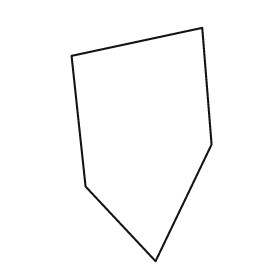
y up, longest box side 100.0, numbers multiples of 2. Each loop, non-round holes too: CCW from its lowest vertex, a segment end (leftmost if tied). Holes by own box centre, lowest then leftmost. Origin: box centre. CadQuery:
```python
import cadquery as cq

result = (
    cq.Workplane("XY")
    .moveTo(6.0, -50.0)
    .lineTo(30.0, 0.0)
    .lineTo(26.0, 50.0)
    .lineTo(-30.0, 38.0)
    .lineTo(-24.0, -18.0)
    .close()
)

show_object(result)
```